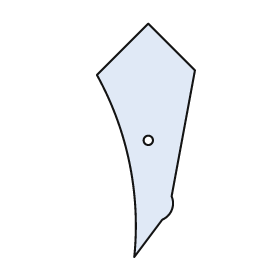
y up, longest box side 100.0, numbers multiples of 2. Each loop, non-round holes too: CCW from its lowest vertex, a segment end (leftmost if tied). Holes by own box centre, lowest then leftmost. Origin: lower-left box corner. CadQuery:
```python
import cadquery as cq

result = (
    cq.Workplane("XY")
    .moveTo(16.0, 0.0)
    .lineTo(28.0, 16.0)
    .threePointArc((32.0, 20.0), (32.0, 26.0))
    .lineTo(42.0, 80.0)
    .lineTo(22.0, 100.0)
    .lineTo(0.0, 78.0)
    .threePointArc((14.0, 40.0), (16.0, 0.0))
    .close()
    .moveTo(22.0, 50.0)
    .circle(2.0)
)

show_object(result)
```